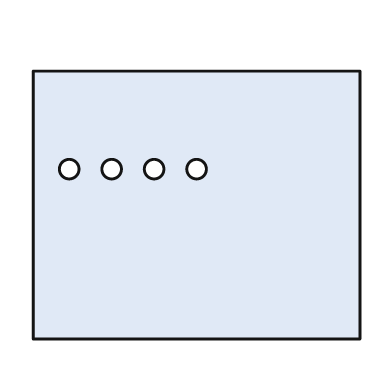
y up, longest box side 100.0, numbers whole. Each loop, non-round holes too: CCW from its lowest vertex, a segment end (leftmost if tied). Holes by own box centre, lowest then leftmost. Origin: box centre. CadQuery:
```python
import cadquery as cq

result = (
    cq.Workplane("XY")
    .moveTo(-50.0, -41.0)
    .lineTo(50.0, -41.0)
    .lineTo(50.0, 41.0)
    .lineTo(-50.0, 41.0)
    .close()
    .moveTo(-39.0, 11.0)
    .circle(3.0)
    .moveTo(-26.0, 11.0)
    .circle(3.0)
    .moveTo(-13.0, 11.0)
    .circle(3.0)
    .moveTo(0.0, 11.0)
    .circle(3.0)
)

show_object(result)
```